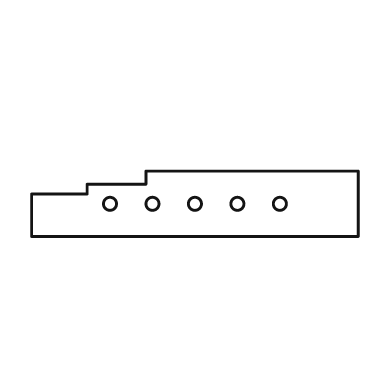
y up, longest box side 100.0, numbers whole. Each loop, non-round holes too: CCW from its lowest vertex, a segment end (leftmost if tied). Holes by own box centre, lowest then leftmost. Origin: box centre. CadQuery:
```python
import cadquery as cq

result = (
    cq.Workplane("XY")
    .moveTo(-50.0, -10.0)
    .lineTo(50.0, -10.0)
    .lineTo(50.0, 10.0)
    .lineTo(-15.0, 10.0)
    .lineTo(-15.0, 6.0)
    .lineTo(-33.0, 6.0)
    .lineTo(-33.0, 3.0)
    .lineTo(-50.0, 3.0)
    .close()
    .moveTo(-26.0, 0.0)
    .circle(2.0)
    .moveTo(-13.0, 0.0)
    .circle(2.0)
    .moveTo(0.0, 0.0)
    .circle(2.0)
    .moveTo(13.0, 0.0)
    .circle(2.0)
    .moveTo(26.0, 0.0)
    .circle(2.0)
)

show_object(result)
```